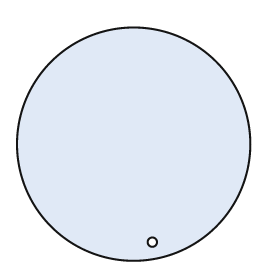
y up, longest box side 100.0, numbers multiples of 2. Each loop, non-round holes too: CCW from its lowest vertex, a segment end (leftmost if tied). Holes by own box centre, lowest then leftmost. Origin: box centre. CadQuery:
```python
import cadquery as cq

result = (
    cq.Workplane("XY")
    .moveTo(0.0, 0.0)
    .circle(50.0)
    .moveTo(8.0, -42.0)
    .circle(2.0)
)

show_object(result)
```